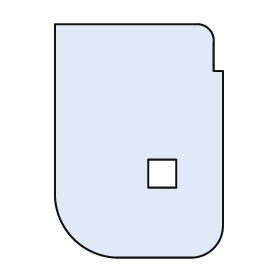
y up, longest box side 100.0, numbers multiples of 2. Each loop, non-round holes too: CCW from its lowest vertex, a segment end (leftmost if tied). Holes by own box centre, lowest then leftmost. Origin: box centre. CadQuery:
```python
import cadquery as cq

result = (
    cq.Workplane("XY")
    .moveTo(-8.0, -50.0)
    .lineTo(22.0, -50.0)
    .threePointArc((32.0, -46.0), (36.0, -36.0))
    .lineTo(36.0, 30.0)
    .lineTo(32.0, 30.0)
    .lineTo(32.0, 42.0)
    .threePointArc((30.0, 48.0), (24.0, 50.0))
    .lineTo(-36.0, 50.0)
    .lineTo(-36.0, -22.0)
    .threePointArc((-28.0, -42.0), (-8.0, -50.0))
    .close()
    .moveTo(4.0, -20.0)
    .lineTo(16.0, -20.0)
    .lineTo(16.0, -8.0)
    .lineTo(4.0, -8.0)
    .close()
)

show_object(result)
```